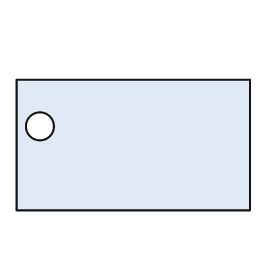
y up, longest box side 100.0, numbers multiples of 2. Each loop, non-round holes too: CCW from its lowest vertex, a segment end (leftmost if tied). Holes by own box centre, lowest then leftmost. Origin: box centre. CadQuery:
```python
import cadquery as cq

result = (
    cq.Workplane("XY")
    .moveTo(-50.0, -28.0)
    .lineTo(50.0, -28.0)
    .lineTo(50.0, 28.0)
    .lineTo(-50.0, 28.0)
    .close()
    .moveTo(-40.0, 8.0)
    .circle(6.0)
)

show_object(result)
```